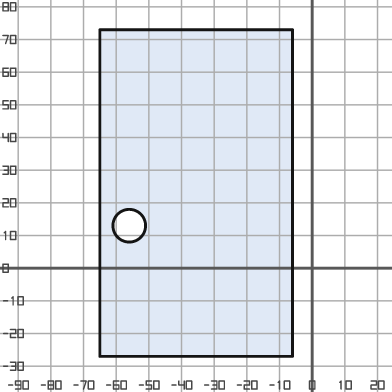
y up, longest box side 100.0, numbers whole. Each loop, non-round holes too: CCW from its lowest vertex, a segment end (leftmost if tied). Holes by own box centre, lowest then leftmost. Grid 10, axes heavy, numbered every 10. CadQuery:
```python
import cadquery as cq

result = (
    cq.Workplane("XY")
    .moveTo(-65.0, -27.0)
    .lineTo(-6.0, -27.0)
    .lineTo(-6.0, 73.0)
    .lineTo(-65.0, 73.0)
    .close()
    .moveTo(-56.0, 13.0)
    .circle(5.0)
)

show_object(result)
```